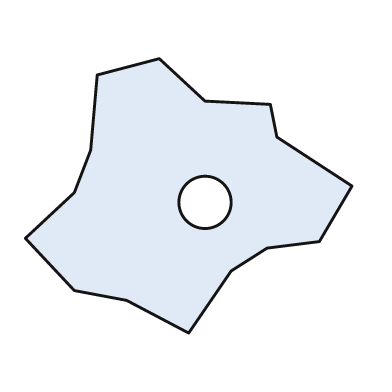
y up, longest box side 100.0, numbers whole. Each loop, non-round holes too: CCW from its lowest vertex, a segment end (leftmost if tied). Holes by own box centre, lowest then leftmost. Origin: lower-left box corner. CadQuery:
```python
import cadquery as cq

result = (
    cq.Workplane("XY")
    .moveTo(50.0, 0.0)
    .lineTo(63.0, 19.0)
    .lineTo(74.0, 26.0)
    .lineTo(90.0, 28.0)
    .lineTo(100.0, 45.0)
    .lineTo(77.0, 60.0)
    .lineTo(75.0, 70.0)
    .lineTo(55.0, 71.0)
    .lineTo(41.0, 84.0)
    .lineTo(22.0, 79.0)
    .lineTo(20.0, 56.0)
    .lineTo(15.0, 43.0)
    .lineTo(0.0, 29.0)
    .lineTo(15.0, 13.0)
    .lineTo(31.0, 10.0)
    .close()
    .moveTo(55.0, 40.0)
    .circle(8.0)
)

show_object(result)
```